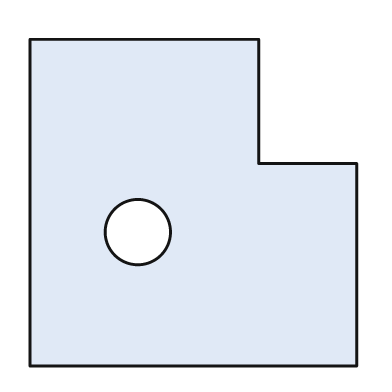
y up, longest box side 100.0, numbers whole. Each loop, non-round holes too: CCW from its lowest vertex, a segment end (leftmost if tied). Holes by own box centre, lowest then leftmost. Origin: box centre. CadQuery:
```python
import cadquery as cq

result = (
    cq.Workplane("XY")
    .moveTo(-50.0, -50.0)
    .lineTo(50.0, -50.0)
    .lineTo(50.0, 12.0)
    .lineTo(20.0, 12.0)
    .lineTo(20.0, 50.0)
    .lineTo(-50.0, 50.0)
    .close()
    .moveTo(-17.0, -9.0)
    .circle(10.0)
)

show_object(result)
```